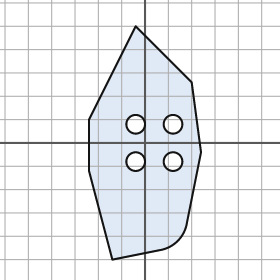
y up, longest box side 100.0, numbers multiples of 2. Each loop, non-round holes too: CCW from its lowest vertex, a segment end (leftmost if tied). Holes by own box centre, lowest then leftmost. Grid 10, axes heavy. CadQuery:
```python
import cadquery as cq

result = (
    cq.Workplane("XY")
    .moveTo(-14.0, -50.0)
    .lineTo(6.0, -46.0)
    .threePointArc((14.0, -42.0), (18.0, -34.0))
    .lineTo(24.0, -4.0)
    .lineTo(20.0, 26.0)
    .lineTo(-4.0, 50.0)
    .lineTo(-24.0, 10.0)
    .lineTo(-24.0, -12.0)
    .close()
    .moveTo(-4.0, -8.0)
    .circle(4.0)
    .moveTo(12.0, -8.0)
    .circle(4.0)
    .moveTo(-4.0, 8.0)
    .circle(4.0)
    .moveTo(12.0, 8.0)
    .circle(4.0)
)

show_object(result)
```